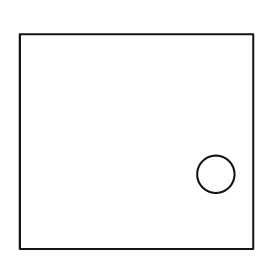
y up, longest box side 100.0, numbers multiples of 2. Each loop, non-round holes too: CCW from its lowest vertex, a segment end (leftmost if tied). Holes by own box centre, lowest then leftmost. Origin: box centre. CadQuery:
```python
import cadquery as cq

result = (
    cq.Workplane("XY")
    .moveTo(-50.0, -46.0)
    .lineTo(50.0, -46.0)
    .lineTo(50.0, 46.0)
    .lineTo(-50.0, 46.0)
    .close()
    .moveTo(34.0, -14.0)
    .circle(8.0)
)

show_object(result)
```